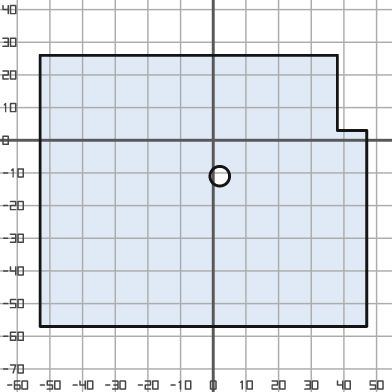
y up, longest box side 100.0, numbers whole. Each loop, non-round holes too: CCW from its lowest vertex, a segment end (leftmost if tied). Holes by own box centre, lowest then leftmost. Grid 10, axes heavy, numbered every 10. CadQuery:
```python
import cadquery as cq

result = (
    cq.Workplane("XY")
    .moveTo(-53.0, -57.0)
    .lineTo(47.0, -57.0)
    .lineTo(47.0, 3.0)
    .lineTo(38.0, 3.0)
    .lineTo(38.0, 26.0)
    .lineTo(-53.0, 26.0)
    .close()
    .moveTo(2.0, -11.0)
    .circle(3.0)
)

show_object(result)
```